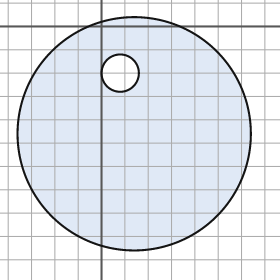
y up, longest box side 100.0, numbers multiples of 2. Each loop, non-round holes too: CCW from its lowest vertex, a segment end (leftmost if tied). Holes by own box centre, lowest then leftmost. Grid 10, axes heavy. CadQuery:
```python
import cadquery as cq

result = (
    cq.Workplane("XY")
    .moveTo(14.0, -46.0)
    .circle(50.0)
    .moveTo(8.0, -20.0)
    .circle(8.0)
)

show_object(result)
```